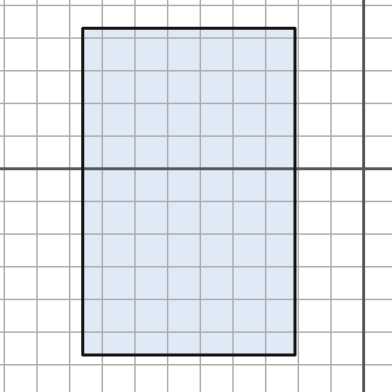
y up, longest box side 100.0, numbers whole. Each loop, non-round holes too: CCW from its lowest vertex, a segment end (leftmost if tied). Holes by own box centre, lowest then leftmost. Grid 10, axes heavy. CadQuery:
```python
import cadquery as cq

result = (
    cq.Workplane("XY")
    .moveTo(-86.0, -57.0)
    .lineTo(-21.0, -57.0)
    .lineTo(-21.0, 43.0)
    .lineTo(-86.0, 43.0)
    .close()
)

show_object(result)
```